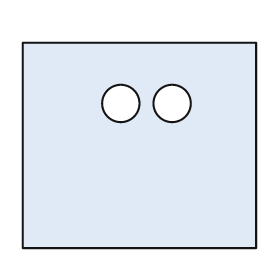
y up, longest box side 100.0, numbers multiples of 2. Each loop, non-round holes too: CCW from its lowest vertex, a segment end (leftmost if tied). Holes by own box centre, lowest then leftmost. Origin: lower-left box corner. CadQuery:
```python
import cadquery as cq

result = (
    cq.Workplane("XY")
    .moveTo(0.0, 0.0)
    .lineTo(100.0, 0.0)
    .lineTo(100.0, 88.0)
    .lineTo(0.0, 88.0)
    .close()
    .moveTo(42.0, 62.0)
    .circle(8.0)
    .moveTo(64.0, 62.0)
    .circle(8.0)
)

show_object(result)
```